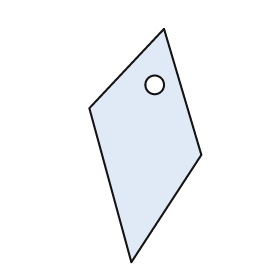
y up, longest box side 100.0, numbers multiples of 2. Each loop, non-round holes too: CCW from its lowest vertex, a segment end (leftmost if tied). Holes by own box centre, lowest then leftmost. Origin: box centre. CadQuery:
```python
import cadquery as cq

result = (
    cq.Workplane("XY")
    .moveTo(-6.0, -50.0)
    .lineTo(24.0, -4.0)
    .lineTo(8.0, 50.0)
    .lineTo(-24.0, 16.0)
    .close()
    .moveTo(4.0, 26.0)
    .circle(4.0)
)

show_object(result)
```